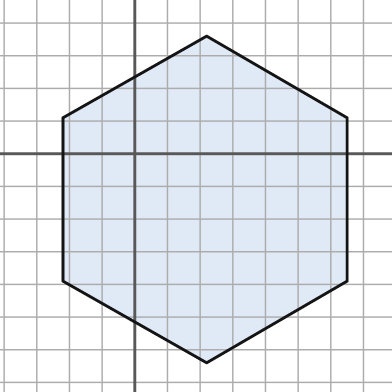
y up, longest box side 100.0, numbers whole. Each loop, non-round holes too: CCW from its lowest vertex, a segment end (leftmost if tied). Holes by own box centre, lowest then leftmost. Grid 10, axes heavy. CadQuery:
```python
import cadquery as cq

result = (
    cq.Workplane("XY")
    .moveTo(22.0, -64.0)
    .lineTo(65.0, -39.0)
    .lineTo(65.0, 11.0)
    .lineTo(22.0, 36.0)
    .lineTo(-22.0, 11.0)
    .lineTo(-22.0, -39.0)
    .close()
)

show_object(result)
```